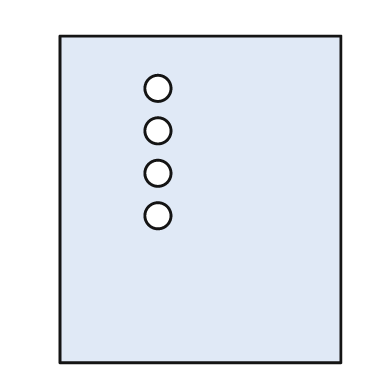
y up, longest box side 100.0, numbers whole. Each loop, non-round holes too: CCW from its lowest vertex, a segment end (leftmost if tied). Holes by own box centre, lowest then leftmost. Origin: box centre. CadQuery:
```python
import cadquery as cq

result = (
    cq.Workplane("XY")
    .moveTo(-43.0, -50.0)
    .lineTo(43.0, -50.0)
    .lineTo(43.0, 50.0)
    .lineTo(-43.0, 50.0)
    .close()
    .moveTo(-13.0, -5.0)
    .circle(4.0)
    .moveTo(-13.0, 8.0)
    .circle(4.0)
    .moveTo(-13.0, 21.0)
    .circle(4.0)
    .moveTo(-13.0, 34.0)
    .circle(4.0)
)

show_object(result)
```